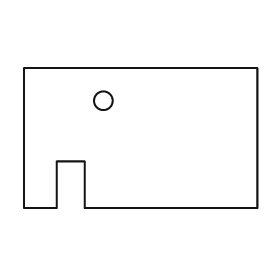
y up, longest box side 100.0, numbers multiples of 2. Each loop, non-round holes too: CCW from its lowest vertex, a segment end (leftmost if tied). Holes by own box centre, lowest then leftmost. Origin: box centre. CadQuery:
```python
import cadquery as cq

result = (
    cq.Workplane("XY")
    .moveTo(-50.0, -30.0)
    .lineTo(-36.0, -30.0)
    .lineTo(-36.0, -10.0)
    .lineTo(-24.0, -10.0)
    .lineTo(-24.0, -30.0)
    .lineTo(50.0, -30.0)
    .lineTo(50.0, 30.0)
    .lineTo(-50.0, 30.0)
    .close()
    .moveTo(-16.0, 16.0)
    .circle(4.0)
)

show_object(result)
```